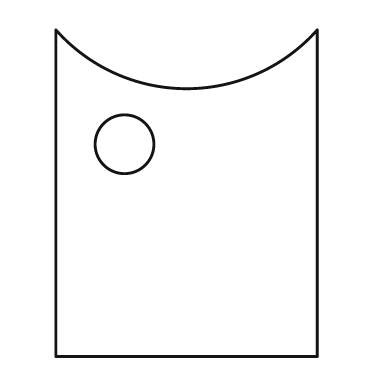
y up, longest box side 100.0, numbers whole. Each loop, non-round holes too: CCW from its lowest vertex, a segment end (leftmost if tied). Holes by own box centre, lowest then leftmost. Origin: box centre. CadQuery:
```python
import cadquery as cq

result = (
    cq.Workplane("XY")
    .moveTo(-40.0, -50.0)
    .lineTo(40.0, -50.0)
    .lineTo(40.0, 50.0)
    .threePointArc((0.0, 32.0), (-40.0, 50.0))
    .close()
    .moveTo(-19.0, 15.0)
    .circle(9.0)
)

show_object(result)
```